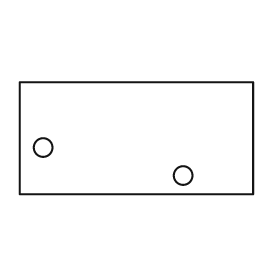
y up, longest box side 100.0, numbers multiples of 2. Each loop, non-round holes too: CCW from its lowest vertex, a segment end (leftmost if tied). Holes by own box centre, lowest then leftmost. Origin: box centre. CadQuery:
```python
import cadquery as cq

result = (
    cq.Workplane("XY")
    .moveTo(-50.0, -24.0)
    .lineTo(50.0, -24.0)
    .lineTo(50.0, 24.0)
    .lineTo(-50.0, 24.0)
    .close()
    .moveTo(20.0, -16.0)
    .circle(4.0)
    .moveTo(-40.0, -4.0)
    .circle(4.0)
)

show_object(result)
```